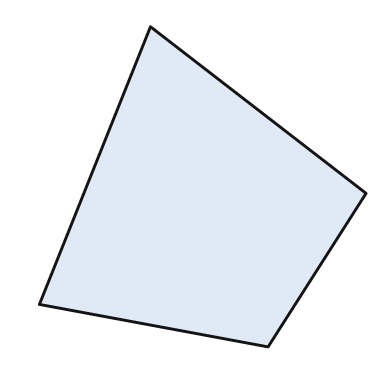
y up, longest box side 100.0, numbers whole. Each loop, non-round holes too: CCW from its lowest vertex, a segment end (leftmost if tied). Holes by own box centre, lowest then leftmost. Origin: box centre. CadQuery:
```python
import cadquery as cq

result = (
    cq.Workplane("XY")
    .moveTo(20.0, -49.0)
    .lineTo(50.0, -2.0)
    .lineTo(-16.0, 49.0)
    .lineTo(-50.0, -36.0)
    .close()
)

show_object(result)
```